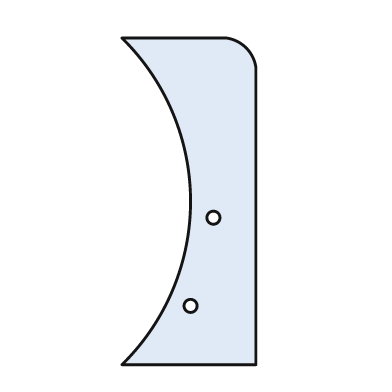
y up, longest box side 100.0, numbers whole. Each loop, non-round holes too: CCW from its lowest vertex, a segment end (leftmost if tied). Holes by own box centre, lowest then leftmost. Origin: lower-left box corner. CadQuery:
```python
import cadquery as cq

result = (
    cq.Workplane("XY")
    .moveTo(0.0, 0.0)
    .lineTo(41.0, 0.0)
    .lineTo(41.0, 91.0)
    .threePointArc((38.0, 97.0), (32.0, 100.0))
    .lineTo(0.0, 100.0)
    .threePointArc((21.0, 50.0), (0.0, 0.0))
    .close()
    .moveTo(21.0, 18.0)
    .circle(2.0)
    .moveTo(28.0, 45.0)
    .circle(2.0)
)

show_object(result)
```